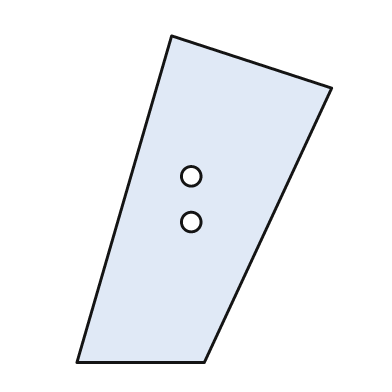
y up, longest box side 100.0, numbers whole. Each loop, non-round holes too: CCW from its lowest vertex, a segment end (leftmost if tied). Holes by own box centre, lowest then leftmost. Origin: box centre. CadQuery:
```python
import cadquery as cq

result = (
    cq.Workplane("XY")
    .moveTo(-39.0, -50.0)
    .lineTo(0.0, -50.0)
    .lineTo(39.0, 34.0)
    .lineTo(-10.0, 50.0)
    .close()
    .moveTo(-4.0, -7.0)
    .circle(3.0)
    .moveTo(-4.0, 7.0)
    .circle(3.0)
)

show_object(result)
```